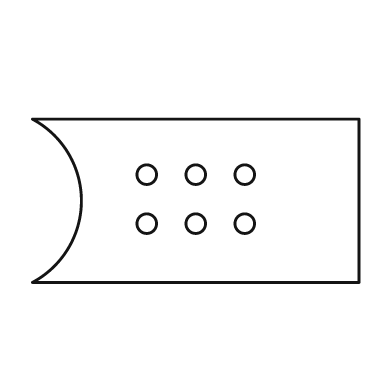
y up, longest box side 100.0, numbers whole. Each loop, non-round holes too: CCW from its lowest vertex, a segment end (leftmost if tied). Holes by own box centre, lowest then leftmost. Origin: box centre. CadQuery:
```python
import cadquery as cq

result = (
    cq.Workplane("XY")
    .moveTo(-50.0, -25.0)
    .lineTo(50.0, -25.0)
    .lineTo(50.0, 25.0)
    .lineTo(-50.0, 25.0)
    .threePointArc((-35.0, 0.0), (-50.0, -25.0))
    .close()
    .moveTo(-15.0, -7.0)
    .circle(3.0)
    .moveTo(0.0, -7.0)
    .circle(3.0)
    .moveTo(15.0, -7.0)
    .circle(3.0)
    .moveTo(-15.0, 8.0)
    .circle(3.0)
    .moveTo(0.0, 8.0)
    .circle(3.0)
    .moveTo(15.0, 8.0)
    .circle(3.0)
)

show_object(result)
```